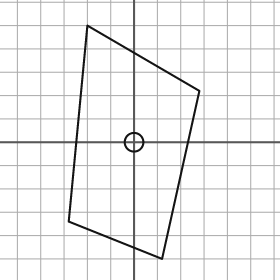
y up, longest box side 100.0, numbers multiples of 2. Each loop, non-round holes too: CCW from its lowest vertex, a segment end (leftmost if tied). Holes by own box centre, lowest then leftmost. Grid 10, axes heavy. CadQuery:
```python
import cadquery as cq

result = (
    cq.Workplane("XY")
    .moveTo(12.0, -50.0)
    .lineTo(28.0, 22.0)
    .lineTo(-20.0, 50.0)
    .lineTo(-28.0, -34.0)
    .close()
    .moveTo(0.0, 0.0)
    .circle(4.0)
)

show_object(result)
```